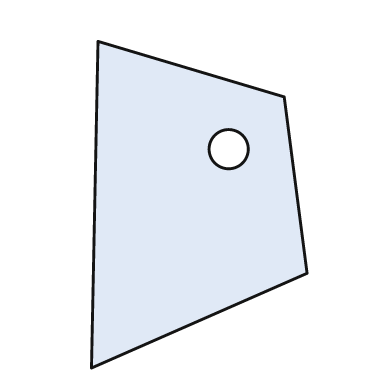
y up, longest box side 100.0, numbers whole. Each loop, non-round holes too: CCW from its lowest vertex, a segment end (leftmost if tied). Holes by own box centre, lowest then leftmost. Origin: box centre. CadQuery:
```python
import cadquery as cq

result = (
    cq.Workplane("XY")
    .moveTo(-33.0, -50.0)
    .lineTo(33.0, -21.0)
    .lineTo(26.0, 33.0)
    .lineTo(-31.0, 50.0)
    .close()
    .moveTo(9.0, 17.0)
    .circle(6.0)
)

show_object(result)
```